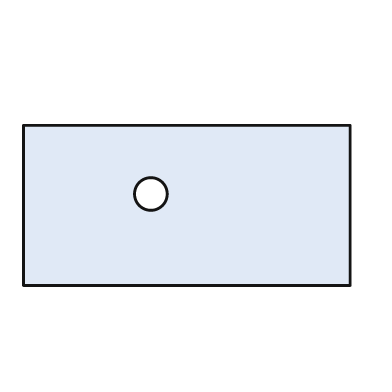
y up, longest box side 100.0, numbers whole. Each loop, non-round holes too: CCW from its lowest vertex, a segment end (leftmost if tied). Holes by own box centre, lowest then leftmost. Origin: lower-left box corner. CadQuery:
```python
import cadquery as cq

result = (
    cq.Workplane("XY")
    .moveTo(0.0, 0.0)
    .lineTo(100.0, 0.0)
    .lineTo(100.0, 49.0)
    .lineTo(0.0, 49.0)
    .close()
    .moveTo(39.0, 28.0)
    .circle(5.0)
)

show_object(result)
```